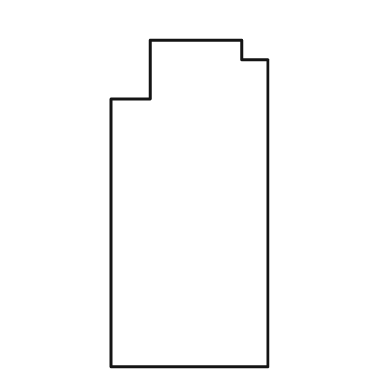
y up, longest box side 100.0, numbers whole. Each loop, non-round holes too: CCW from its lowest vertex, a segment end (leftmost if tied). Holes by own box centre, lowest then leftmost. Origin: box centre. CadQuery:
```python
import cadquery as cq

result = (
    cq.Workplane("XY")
    .moveTo(-24.0, -50.0)
    .lineTo(24.0, -50.0)
    .lineTo(24.0, 44.0)
    .lineTo(16.0, 44.0)
    .lineTo(16.0, 50.0)
    .lineTo(-12.0, 50.0)
    .lineTo(-12.0, 32.0)
    .lineTo(-24.0, 32.0)
    .close()
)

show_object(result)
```